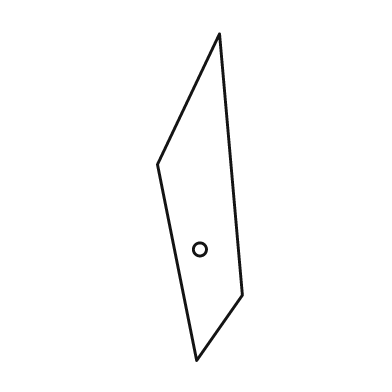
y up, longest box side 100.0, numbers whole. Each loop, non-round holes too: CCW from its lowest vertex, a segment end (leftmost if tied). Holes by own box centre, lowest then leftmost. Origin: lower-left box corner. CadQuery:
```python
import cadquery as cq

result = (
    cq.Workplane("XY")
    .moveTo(12.0, 0.0)
    .lineTo(26.0, 20.0)
    .lineTo(19.0, 100.0)
    .lineTo(0.0, 60.0)
    .close()
    .moveTo(13.0, 34.0)
    .circle(2.0)
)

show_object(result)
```